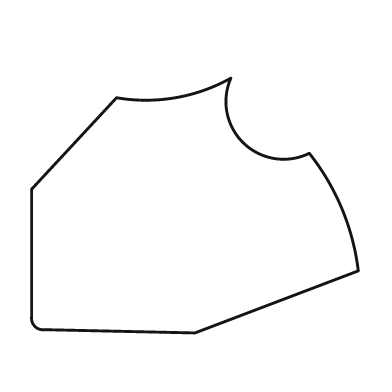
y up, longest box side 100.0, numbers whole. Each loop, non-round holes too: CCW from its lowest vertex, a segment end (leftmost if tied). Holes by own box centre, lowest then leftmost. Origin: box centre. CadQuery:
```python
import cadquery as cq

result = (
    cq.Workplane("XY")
    .moveTo(0.0, -39.0)
    .lineTo(50.0, -20.0)
    .threePointArc((45.0, -1.0), (35.0, 16.0))
    .threePointArc((15.0, 19.0), (11.0, 39.0))
    .threePointArc((-6.0, 33.0), (-24.0, 33.0))
    .lineTo(-50.0, 5.0)
    .lineTo(-50.0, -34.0)
    .threePointArc((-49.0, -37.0), (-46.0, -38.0))
    .close()
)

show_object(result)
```